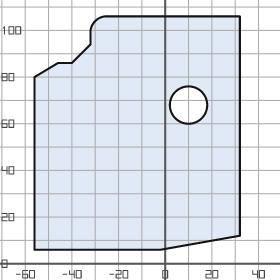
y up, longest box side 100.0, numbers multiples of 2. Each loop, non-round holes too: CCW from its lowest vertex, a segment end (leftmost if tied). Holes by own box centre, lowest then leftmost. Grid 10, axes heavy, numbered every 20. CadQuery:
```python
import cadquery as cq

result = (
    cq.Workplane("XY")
    .moveTo(-56.0, 6.0)
    .lineTo(-2.0, 6.0)
    .lineTo(32.0, 12.0)
    .lineTo(32.0, 106.0)
    .lineTo(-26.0, 106.0)
    .threePointArc((-30.0, 104.0), (-32.0, 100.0))
    .lineTo(-32.0, 94.0)
    .lineTo(-40.0, 86.0)
    .lineTo(-46.0, 86.0)
    .lineTo(-56.0, 80.0)
    .close()
    .moveTo(10.0, 68.0)
    .circle(8.0)
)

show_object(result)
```